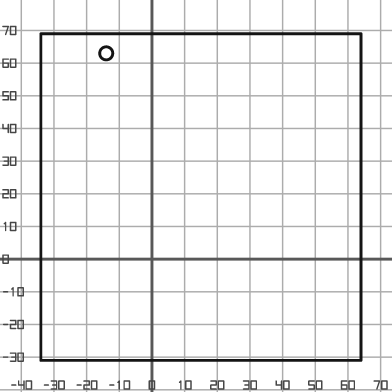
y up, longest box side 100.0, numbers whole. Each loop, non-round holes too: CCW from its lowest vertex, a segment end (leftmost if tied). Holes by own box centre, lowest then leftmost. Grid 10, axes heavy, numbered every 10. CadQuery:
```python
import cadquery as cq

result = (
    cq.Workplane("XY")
    .moveTo(-34.0, -31.0)
    .lineTo(64.0, -31.0)
    .lineTo(64.0, 69.0)
    .lineTo(-34.0, 69.0)
    .close()
    .moveTo(-14.0, 63.0)
    .circle(2.0)
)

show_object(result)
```